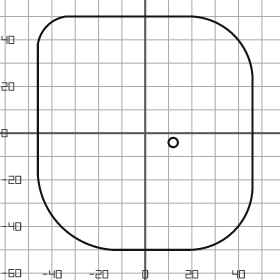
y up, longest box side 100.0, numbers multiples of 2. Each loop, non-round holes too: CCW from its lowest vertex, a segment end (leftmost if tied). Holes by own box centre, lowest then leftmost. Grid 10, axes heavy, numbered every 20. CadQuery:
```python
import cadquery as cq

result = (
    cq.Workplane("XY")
    .moveTo(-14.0, -50.0)
    .lineTo(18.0, -50.0)
    .threePointArc((38.0, -42.0), (46.0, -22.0))
    .lineTo(46.0, 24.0)
    .threePointArc((38.0, 42.0), (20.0, 50.0))
    .lineTo(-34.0, 50.0)
    .threePointArc((-42.0, 46.0), (-46.0, 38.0))
    .lineTo(-46.0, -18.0)
    .threePointArc((-36.0, -40.0), (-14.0, -50.0))
    .close()
    .moveTo(12.0, -4.0)
    .circle(2.0)
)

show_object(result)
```